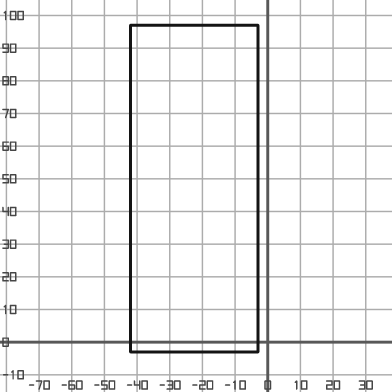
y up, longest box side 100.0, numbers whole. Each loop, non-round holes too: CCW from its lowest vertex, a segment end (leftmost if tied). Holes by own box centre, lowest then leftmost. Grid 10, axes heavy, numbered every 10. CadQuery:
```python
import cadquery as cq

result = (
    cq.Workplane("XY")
    .moveTo(-42.0, -3.0)
    .lineTo(-3.0, -3.0)
    .lineTo(-3.0, 97.0)
    .lineTo(-42.0, 97.0)
    .close()
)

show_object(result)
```